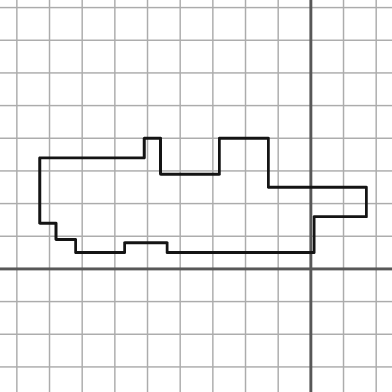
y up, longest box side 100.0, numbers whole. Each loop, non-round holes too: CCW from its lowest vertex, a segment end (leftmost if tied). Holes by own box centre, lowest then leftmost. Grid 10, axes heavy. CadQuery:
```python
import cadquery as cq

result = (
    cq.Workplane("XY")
    .moveTo(-72.0, 5.0)
    .lineTo(-57.0, 5.0)
    .lineTo(-57.0, 8.0)
    .lineTo(-44.0, 8.0)
    .lineTo(-44.0, 5.0)
    .lineTo(1.0, 5.0)
    .lineTo(1.0, 16.0)
    .lineTo(17.0, 16.0)
    .lineTo(17.0, 25.0)
    .lineTo(-13.0, 25.0)
    .lineTo(-13.0, 40.0)
    .lineTo(-28.0, 40.0)
    .lineTo(-28.0, 29.0)
    .lineTo(-46.0, 29.0)
    .lineTo(-46.0, 40.0)
    .lineTo(-51.0, 40.0)
    .lineTo(-51.0, 34.0)
    .lineTo(-83.0, 34.0)
    .lineTo(-83.0, 14.0)
    .lineTo(-78.0, 14.0)
    .lineTo(-78.0, 9.0)
    .lineTo(-72.0, 9.0)
    .close()
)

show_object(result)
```